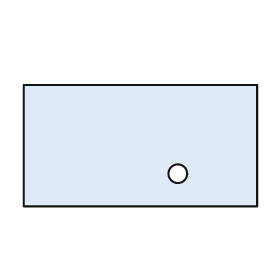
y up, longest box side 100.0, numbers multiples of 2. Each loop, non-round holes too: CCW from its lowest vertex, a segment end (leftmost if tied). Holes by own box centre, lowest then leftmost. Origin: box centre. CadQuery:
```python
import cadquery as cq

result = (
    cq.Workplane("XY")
    .moveTo(-50.0, -26.0)
    .lineTo(50.0, -26.0)
    .lineTo(50.0, 26.0)
    .lineTo(-50.0, 26.0)
    .close()
    .moveTo(16.0, -12.0)
    .circle(4.0)
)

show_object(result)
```